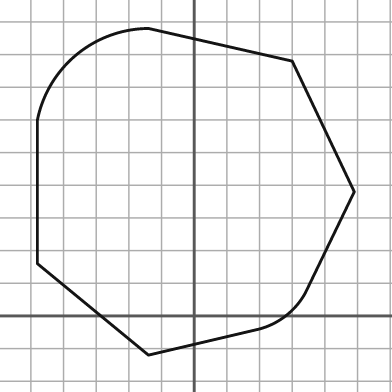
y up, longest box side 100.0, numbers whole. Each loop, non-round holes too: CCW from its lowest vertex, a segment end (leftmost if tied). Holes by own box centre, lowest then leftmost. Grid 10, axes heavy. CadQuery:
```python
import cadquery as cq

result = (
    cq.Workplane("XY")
    .moveTo(-14.0, -12.0)
    .lineTo(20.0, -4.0)
    .threePointArc((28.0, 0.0), (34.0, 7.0))
    .lineTo(49.0, 38.0)
    .lineTo(30.0, 78.0)
    .lineTo(-14.0, 88.0)
    .threePointArc((-36.0, 80.0), (-48.0, 60.0))
    .lineTo(-48.0, 16.0)
    .close()
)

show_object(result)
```